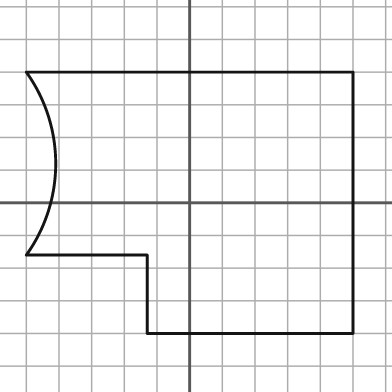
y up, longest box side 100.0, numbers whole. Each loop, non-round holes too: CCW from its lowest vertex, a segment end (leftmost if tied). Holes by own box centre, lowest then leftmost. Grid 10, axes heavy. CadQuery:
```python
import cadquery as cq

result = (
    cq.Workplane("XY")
    .moveTo(-13.0, -40.0)
    .lineTo(50.0, -40.0)
    .lineTo(50.0, 40.0)
    .lineTo(-50.0, 40.0)
    .threePointArc((-41.0, 12.0), (-50.0, -16.0))
    .lineTo(-13.0, -16.0)
    .close()
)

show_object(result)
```